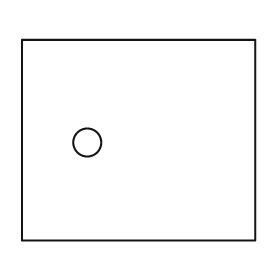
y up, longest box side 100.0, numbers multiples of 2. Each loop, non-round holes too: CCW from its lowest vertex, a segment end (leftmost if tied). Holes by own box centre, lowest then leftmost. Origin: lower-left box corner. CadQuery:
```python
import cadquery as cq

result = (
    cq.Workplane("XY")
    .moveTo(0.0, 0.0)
    .lineTo(100.0, 0.0)
    .lineTo(100.0, 86.0)
    .lineTo(0.0, 86.0)
    .close()
    .moveTo(28.0, 42.0)
    .circle(6.0)
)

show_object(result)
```